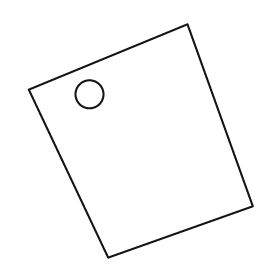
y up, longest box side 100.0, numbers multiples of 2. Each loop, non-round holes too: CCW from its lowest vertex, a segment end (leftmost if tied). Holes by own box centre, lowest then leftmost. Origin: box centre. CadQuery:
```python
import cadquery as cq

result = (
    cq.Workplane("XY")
    .moveTo(-14.0, -50.0)
    .lineTo(48.0, -28.0)
    .lineTo(20.0, 50.0)
    .lineTo(-48.0, 22.0)
    .close()
    .moveTo(-22.0, 20.0)
    .circle(6.0)
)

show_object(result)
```